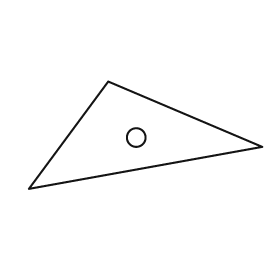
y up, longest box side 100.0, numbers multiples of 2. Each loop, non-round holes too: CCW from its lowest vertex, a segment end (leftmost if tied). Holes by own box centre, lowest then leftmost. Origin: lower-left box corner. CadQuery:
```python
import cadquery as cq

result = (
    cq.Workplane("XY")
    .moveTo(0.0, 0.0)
    .lineTo(100.0, 18.0)
    .lineTo(34.0, 46.0)
    .close()
    .moveTo(46.0, 22.0)
    .circle(4.0)
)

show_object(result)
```